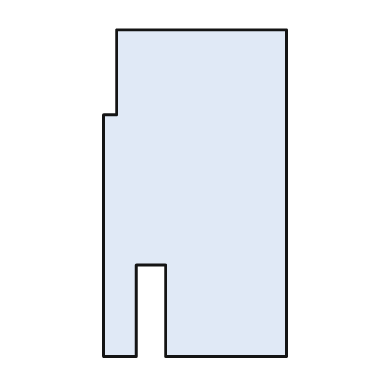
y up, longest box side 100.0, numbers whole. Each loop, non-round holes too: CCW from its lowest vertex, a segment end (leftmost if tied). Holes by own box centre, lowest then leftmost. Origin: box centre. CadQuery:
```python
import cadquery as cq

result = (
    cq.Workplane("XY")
    .moveTo(-28.0, -50.0)
    .lineTo(-18.0, -50.0)
    .lineTo(-18.0, -22.0)
    .lineTo(-9.0, -22.0)
    .lineTo(-9.0, -50.0)
    .lineTo(28.0, -50.0)
    .lineTo(28.0, 50.0)
    .lineTo(-24.0, 50.0)
    .lineTo(-24.0, 24.0)
    .lineTo(-28.0, 24.0)
    .close()
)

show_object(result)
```